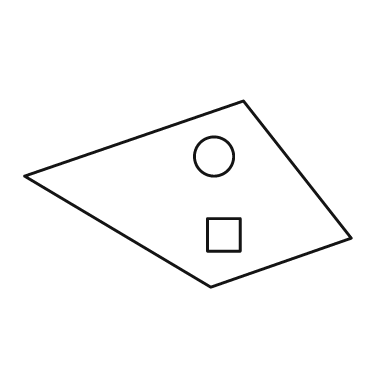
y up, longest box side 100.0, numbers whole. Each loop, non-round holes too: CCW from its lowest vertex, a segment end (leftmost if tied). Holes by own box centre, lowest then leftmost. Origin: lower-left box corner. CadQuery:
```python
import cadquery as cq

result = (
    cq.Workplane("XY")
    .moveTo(57.0, 0.0)
    .lineTo(100.0, 15.0)
    .lineTo(67.0, 57.0)
    .lineTo(0.0, 34.0)
    .close()
    .moveTo(56.0, 11.0)
    .lineTo(66.0, 11.0)
    .lineTo(66.0, 21.0)
    .lineTo(56.0, 21.0)
    .close()
    .moveTo(58.0, 40.0)
    .circle(6.0)
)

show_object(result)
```